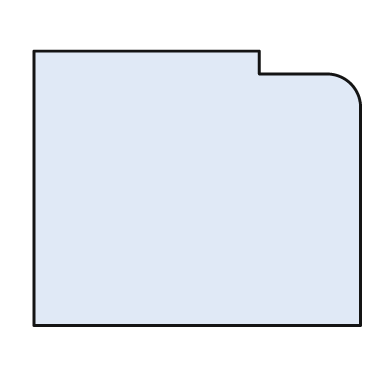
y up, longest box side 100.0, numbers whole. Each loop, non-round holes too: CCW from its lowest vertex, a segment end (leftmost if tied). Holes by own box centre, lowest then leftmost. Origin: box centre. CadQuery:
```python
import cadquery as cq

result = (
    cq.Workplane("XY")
    .moveTo(-50.0, -42.0)
    .lineTo(50.0, -42.0)
    .lineTo(50.0, 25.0)
    .threePointArc((47.0, 32.0), (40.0, 35.0))
    .lineTo(19.0, 35.0)
    .lineTo(19.0, 42.0)
    .lineTo(-50.0, 42.0)
    .close()
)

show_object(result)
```